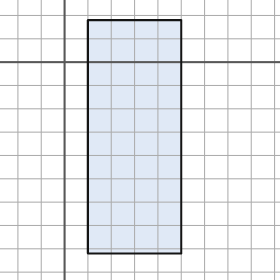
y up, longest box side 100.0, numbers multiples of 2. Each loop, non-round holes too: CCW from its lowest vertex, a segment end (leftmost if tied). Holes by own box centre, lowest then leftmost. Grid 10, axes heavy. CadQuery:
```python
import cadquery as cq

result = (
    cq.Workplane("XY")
    .moveTo(10.0, -82.0)
    .lineTo(50.0, -82.0)
    .lineTo(50.0, 18.0)
    .lineTo(10.0, 18.0)
    .close()
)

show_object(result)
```